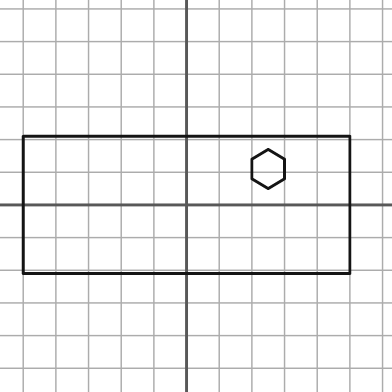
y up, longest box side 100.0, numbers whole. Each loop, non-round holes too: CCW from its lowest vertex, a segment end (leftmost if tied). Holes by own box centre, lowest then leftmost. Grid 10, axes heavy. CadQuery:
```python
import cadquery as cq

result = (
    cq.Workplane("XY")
    .moveTo(-50.0, -21.0)
    .lineTo(50.0, -21.0)
    .lineTo(50.0, 21.0)
    .lineTo(-50.0, 21.0)
    .close()
    .moveTo(25.0, 5.0)
    .lineTo(30.0, 8.0)
    .lineTo(30.0, 14.0)
    .lineTo(25.0, 17.0)
    .lineTo(20.0, 14.0)
    .lineTo(20.0, 8.0)
    .close()
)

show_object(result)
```